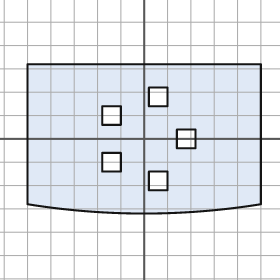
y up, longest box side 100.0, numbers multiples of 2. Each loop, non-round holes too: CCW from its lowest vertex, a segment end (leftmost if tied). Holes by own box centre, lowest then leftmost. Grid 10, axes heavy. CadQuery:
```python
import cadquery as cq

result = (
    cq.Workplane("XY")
    .moveTo(-50.0, -28.0)
    .threePointArc((0.0, -32.0), (50.0, -28.0))
    .lineTo(50.0, 32.0)
    .lineTo(-50.0, 32.0)
    .close()
    .moveTo(2.0, -22.0)
    .lineTo(10.0, -22.0)
    .lineTo(10.0, -14.0)
    .lineTo(2.0, -14.0)
    .close()
    .moveTo(-18.0, -14.0)
    .lineTo(-10.0, -14.0)
    .lineTo(-10.0, -6.0)
    .lineTo(-18.0, -6.0)
    .close()
    .moveTo(14.0, -4.0)
    .lineTo(22.0, -4.0)
    .lineTo(22.0, 4.0)
    .lineTo(14.0, 4.0)
    .close()
    .moveTo(-18.0, 6.0)
    .lineTo(-10.0, 6.0)
    .lineTo(-10.0, 14.0)
    .lineTo(-18.0, 14.0)
    .close()
    .moveTo(2.0, 14.0)
    .lineTo(10.0, 14.0)
    .lineTo(10.0, 22.0)
    .lineTo(2.0, 22.0)
    .close()
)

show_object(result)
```